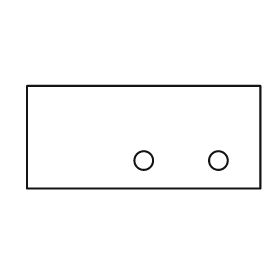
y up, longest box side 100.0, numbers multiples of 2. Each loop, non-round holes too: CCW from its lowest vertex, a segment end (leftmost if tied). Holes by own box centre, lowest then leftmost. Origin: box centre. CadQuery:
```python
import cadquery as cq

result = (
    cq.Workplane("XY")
    .moveTo(-50.0, -22.0)
    .lineTo(50.0, -22.0)
    .lineTo(50.0, 22.0)
    .lineTo(-50.0, 22.0)
    .close()
    .moveTo(0.0, -10.0)
    .circle(4.0)
    .moveTo(32.0, -10.0)
    .circle(4.0)
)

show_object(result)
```